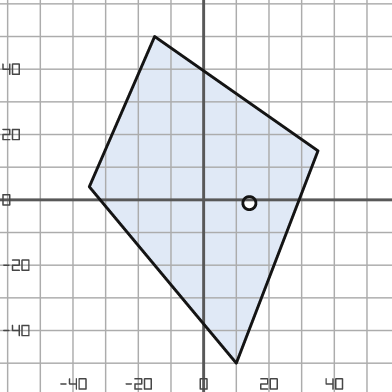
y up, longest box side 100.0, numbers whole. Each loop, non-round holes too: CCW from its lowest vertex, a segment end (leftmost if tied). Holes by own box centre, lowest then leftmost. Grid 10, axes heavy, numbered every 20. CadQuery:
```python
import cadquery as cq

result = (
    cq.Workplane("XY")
    .moveTo(10.0, -50.0)
    .lineTo(35.0, 15.0)
    .lineTo(-15.0, 50.0)
    .lineTo(-35.0, 4.0)
    .close()
    .moveTo(14.0, -1.0)
    .circle(2.0)
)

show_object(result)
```